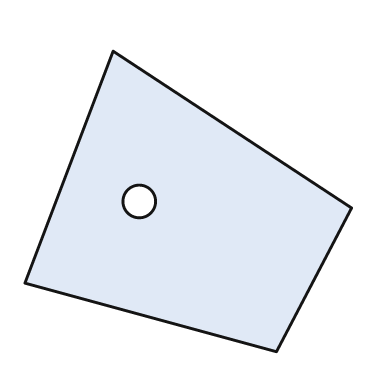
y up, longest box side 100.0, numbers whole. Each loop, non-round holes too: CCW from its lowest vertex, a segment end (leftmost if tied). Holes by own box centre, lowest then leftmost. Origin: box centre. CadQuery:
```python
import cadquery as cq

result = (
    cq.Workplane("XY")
    .moveTo(27.0, -46.0)
    .lineTo(50.0, -2.0)
    .lineTo(-23.0, 46.0)
    .lineTo(-50.0, -25.0)
    .close()
    .moveTo(-15.0, 0.0)
    .circle(5.0)
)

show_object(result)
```